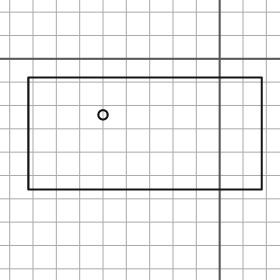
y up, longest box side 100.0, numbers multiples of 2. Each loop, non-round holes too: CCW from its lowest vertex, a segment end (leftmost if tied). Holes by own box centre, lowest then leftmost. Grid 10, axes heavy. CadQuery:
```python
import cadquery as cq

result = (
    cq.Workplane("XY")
    .moveTo(-82.0, -56.0)
    .lineTo(18.0, -56.0)
    .lineTo(18.0, -8.0)
    .lineTo(-82.0, -8.0)
    .close()
    .moveTo(-50.0, -24.0)
    .circle(2.0)
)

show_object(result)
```